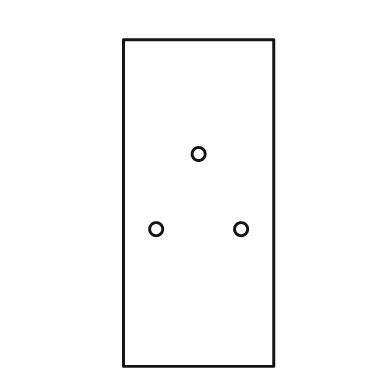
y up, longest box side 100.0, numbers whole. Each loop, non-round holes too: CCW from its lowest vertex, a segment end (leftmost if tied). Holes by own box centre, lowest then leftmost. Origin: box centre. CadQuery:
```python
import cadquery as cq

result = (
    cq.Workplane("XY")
    .moveTo(-23.0, -50.0)
    .lineTo(23.0, -50.0)
    .lineTo(23.0, 50.0)
    .lineTo(-23.0, 50.0)
    .close()
    .moveTo(-13.0, -8.0)
    .circle(2.0)
    .moveTo(13.0, -8.0)
    .circle(2.0)
    .moveTo(0.0, 15.0)
    .circle(2.0)
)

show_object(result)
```